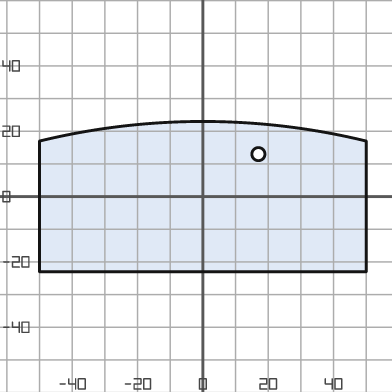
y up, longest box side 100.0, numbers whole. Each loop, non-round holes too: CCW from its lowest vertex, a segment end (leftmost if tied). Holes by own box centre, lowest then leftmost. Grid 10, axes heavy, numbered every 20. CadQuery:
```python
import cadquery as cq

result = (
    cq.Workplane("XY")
    .moveTo(-50.0, -23.0)
    .lineTo(50.0, -23.0)
    .lineTo(50.0, 17.0)
    .threePointArc((0.0, 23.0), (-50.0, 17.0))
    .close()
    .moveTo(17.0, 13.0)
    .circle(2.0)
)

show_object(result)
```